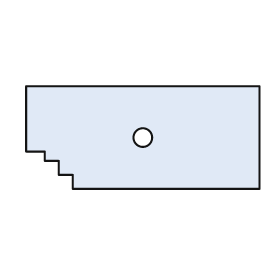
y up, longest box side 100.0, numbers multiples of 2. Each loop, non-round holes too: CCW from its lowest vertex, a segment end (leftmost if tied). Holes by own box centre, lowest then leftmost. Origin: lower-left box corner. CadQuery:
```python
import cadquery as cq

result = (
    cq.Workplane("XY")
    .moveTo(20.0, 0.0)
    .lineTo(100.0, 0.0)
    .lineTo(100.0, 44.0)
    .lineTo(0.0, 44.0)
    .lineTo(0.0, 16.0)
    .lineTo(8.0, 16.0)
    .lineTo(8.0, 12.0)
    .lineTo(14.0, 12.0)
    .lineTo(14.0, 6.0)
    .lineTo(20.0, 6.0)
    .close()
    .moveTo(50.0, 22.0)
    .circle(4.0)
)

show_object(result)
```